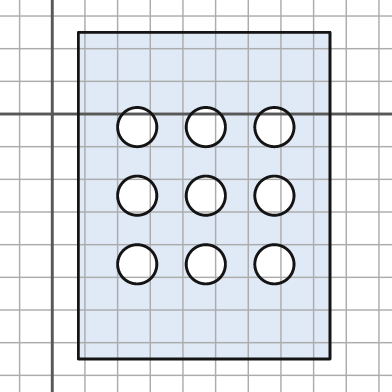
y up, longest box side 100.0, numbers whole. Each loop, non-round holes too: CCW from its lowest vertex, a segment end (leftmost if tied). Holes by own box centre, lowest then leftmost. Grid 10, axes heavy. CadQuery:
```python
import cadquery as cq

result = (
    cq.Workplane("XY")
    .moveTo(8.0, -75.0)
    .lineTo(85.0, -75.0)
    .lineTo(85.0, 25.0)
    .lineTo(8.0, 25.0)
    .close()
    .moveTo(26.0, -46.0)
    .circle(6.0)
    .moveTo(47.0, -46.0)
    .circle(6.0)
    .moveTo(68.0, -46.0)
    .circle(6.0)
    .moveTo(26.0, -25.0)
    .circle(6.0)
    .moveTo(47.0, -25.0)
    .circle(6.0)
    .moveTo(68.0, -25.0)
    .circle(6.0)
    .moveTo(26.0, -4.0)
    .circle(6.0)
    .moveTo(47.0, -4.0)
    .circle(6.0)
    .moveTo(68.0, -4.0)
    .circle(6.0)
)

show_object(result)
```